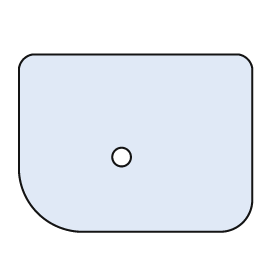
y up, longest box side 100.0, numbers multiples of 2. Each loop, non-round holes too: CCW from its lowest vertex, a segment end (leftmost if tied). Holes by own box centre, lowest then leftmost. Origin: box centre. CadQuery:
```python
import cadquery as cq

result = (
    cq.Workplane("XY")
    .moveTo(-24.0, -38.0)
    .lineTo(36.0, -38.0)
    .threePointArc((46.0, -34.0), (50.0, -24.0))
    .lineTo(50.0, 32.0)
    .threePointArc((48.0, 36.0), (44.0, 38.0))
    .lineTo(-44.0, 38.0)
    .threePointArc((-48.0, 36.0), (-50.0, 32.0))
    .lineTo(-50.0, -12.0)
    .threePointArc((-42.0, -30.0), (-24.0, -38.0))
    .close()
    .moveTo(-6.0, -6.0)
    .circle(4.0)
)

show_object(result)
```